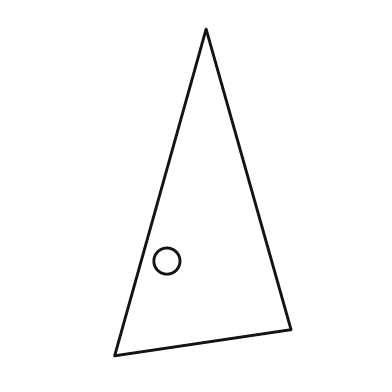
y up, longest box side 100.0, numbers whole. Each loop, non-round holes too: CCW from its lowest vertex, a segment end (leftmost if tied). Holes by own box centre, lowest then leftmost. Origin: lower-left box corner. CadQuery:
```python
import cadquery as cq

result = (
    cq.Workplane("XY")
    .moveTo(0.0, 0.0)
    .lineTo(54.0, 8.0)
    .lineTo(28.0, 100.0)
    .close()
    .moveTo(16.0, 29.0)
    .circle(4.0)
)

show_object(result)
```